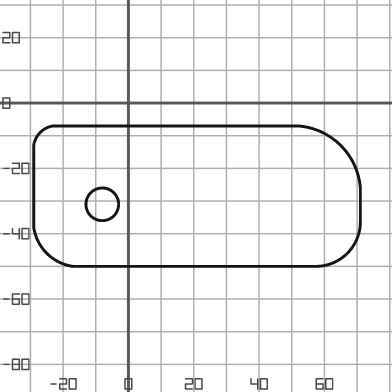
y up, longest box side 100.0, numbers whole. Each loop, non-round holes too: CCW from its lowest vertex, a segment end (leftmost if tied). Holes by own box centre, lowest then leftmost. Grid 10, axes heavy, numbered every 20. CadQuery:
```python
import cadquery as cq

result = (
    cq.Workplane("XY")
    .moveTo(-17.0, -50.0)
    .lineTo(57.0, -50.0)
    .threePointArc((67.0, -46.0), (71.0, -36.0))
    .lineTo(71.0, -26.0)
    .threePointArc((65.0, -13.0), (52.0, -7.0))
    .lineTo(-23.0, -7.0)
    .threePointArc((-27.0, -9.0), (-29.0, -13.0))
    .lineTo(-29.0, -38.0)
    .threePointArc((-25.0, -46.0), (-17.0, -50.0))
    .close()
    .moveTo(-8.0, -31.0)
    .circle(5.0)
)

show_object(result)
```